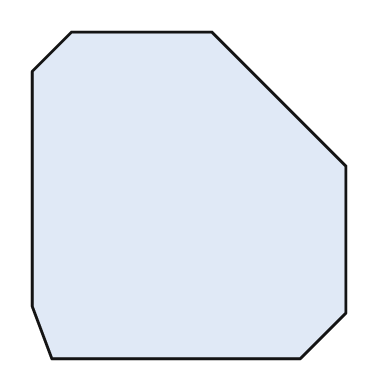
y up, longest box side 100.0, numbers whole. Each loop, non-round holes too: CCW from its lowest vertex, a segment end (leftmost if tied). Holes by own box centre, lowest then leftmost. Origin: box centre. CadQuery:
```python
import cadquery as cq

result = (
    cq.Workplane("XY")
    .moveTo(-42.0, -50.0)
    .lineTo(34.0, -50.0)
    .lineTo(48.0, -36.0)
    .lineTo(48.0, 9.0)
    .lineTo(7.0, 50.0)
    .lineTo(-36.0, 50.0)
    .lineTo(-48.0, 38.0)
    .lineTo(-48.0, -34.0)
    .close()
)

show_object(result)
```